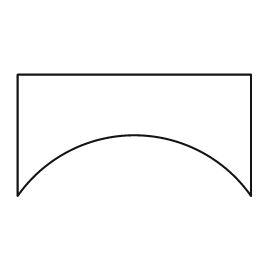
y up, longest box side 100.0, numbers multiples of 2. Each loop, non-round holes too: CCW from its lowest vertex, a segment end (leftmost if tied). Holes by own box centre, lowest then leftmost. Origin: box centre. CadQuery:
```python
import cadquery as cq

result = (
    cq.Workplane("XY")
    .moveTo(-50.0, -26.0)
    .threePointArc((0.0, 0.0), (50.0, -26.0))
    .lineTo(50.0, 26.0)
    .lineTo(-50.0, 26.0)
    .close()
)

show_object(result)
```